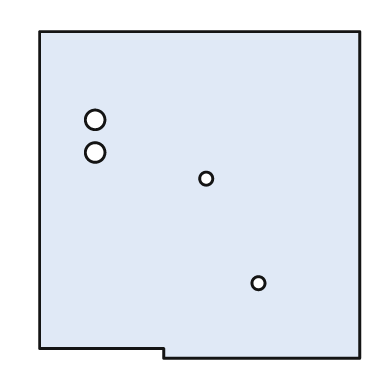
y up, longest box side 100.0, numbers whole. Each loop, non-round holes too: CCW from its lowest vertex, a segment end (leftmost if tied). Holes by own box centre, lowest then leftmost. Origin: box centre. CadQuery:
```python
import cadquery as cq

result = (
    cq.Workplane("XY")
    .moveTo(-11.0, -50.0)
    .lineTo(49.0, -50.0)
    .lineTo(49.0, 50.0)
    .lineTo(-49.0, 50.0)
    .lineTo(-49.0, -47.0)
    .lineTo(-11.0, -47.0)
    .close()
    .moveTo(18.0, -27.0)
    .circle(2.0)
    .moveTo(2.0, 5.0)
    .circle(2.0)
    .moveTo(-32.0, 13.0)
    .circle(3.0)
    .moveTo(-32.0, 23.0)
    .circle(3.0)
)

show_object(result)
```